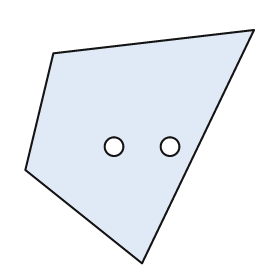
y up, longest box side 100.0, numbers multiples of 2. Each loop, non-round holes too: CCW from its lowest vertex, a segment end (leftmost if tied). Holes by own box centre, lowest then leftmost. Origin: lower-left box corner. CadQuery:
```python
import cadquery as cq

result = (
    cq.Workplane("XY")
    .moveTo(50.0, 0.0)
    .lineTo(98.0, 100.0)
    .lineTo(12.0, 90.0)
    .lineTo(0.0, 40.0)
    .close()
    .moveTo(38.0, 50.0)
    .circle(4.0)
    .moveTo(62.0, 50.0)
    .circle(4.0)
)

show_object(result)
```